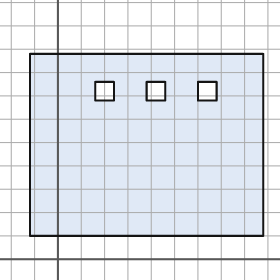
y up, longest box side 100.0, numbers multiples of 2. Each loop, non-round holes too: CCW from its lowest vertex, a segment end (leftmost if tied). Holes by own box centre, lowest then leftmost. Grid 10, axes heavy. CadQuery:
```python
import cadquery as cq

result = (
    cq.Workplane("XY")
    .moveTo(-12.0, 10.0)
    .lineTo(88.0, 10.0)
    .lineTo(88.0, 88.0)
    .lineTo(-12.0, 88.0)
    .close()
    .moveTo(16.0, 68.0)
    .lineTo(24.0, 68.0)
    .lineTo(24.0, 76.0)
    .lineTo(16.0, 76.0)
    .close()
    .moveTo(38.0, 68.0)
    .lineTo(46.0, 68.0)
    .lineTo(46.0, 76.0)
    .lineTo(38.0, 76.0)
    .close()
    .moveTo(60.0, 68.0)
    .lineTo(68.0, 68.0)
    .lineTo(68.0, 76.0)
    .lineTo(60.0, 76.0)
    .close()
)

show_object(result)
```